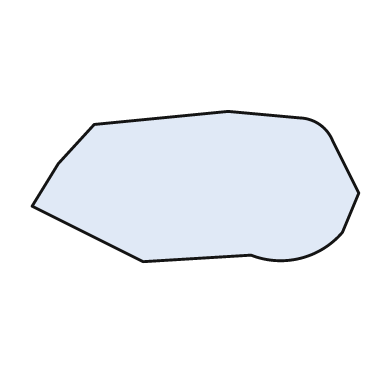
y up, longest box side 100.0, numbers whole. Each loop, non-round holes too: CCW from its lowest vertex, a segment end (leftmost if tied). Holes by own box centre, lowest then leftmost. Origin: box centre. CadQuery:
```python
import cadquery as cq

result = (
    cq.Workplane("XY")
    .moveTo(-16.0, -23.0)
    .lineTo(17.0, -21.0)
    .threePointArc((32.0, -22.0), (45.0, -14.0))
    .lineTo(50.0, -2.0)
    .lineTo(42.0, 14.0)
    .threePointArc((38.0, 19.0), (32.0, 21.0))
    .lineTo(10.0, 23.0)
    .lineTo(-31.0, 19.0)
    .lineTo(-42.0, 7.0)
    .lineTo(-50.0, -6.0)
    .close()
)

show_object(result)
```